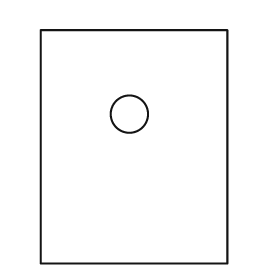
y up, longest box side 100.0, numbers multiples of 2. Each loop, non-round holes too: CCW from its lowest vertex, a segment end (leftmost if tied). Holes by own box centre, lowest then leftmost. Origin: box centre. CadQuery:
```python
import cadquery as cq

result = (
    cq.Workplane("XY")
    .moveTo(-40.0, -50.0)
    .lineTo(40.0, -50.0)
    .lineTo(40.0, 50.0)
    .lineTo(-40.0, 50.0)
    .close()
    .moveTo(-2.0, 14.0)
    .circle(8.0)
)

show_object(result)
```